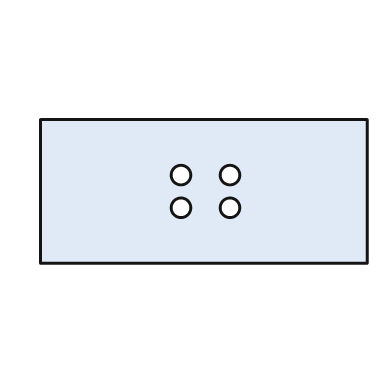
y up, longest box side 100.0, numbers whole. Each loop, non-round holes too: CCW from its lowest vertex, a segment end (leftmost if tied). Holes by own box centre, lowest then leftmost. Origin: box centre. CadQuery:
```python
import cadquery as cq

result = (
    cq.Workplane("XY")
    .moveTo(-50.0, -22.0)
    .lineTo(50.0, -22.0)
    .lineTo(50.0, 22.0)
    .lineTo(-50.0, 22.0)
    .close()
    .moveTo(-7.0, -5.0)
    .circle(3.0)
    .moveTo(8.0, -5.0)
    .circle(3.0)
    .moveTo(-7.0, 5.0)
    .circle(3.0)
    .moveTo(8.0, 5.0)
    .circle(3.0)
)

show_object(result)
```